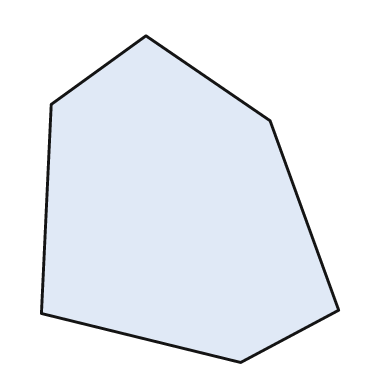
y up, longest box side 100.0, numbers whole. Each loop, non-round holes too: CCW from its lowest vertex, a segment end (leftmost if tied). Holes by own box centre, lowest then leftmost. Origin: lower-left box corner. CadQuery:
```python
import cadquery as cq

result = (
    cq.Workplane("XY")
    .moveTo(61.0, 0.0)
    .lineTo(91.0, 16.0)
    .lineTo(70.0, 74.0)
    .lineTo(32.0, 100.0)
    .lineTo(3.0, 79.0)
    .lineTo(0.0, 15.0)
    .close()
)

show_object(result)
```